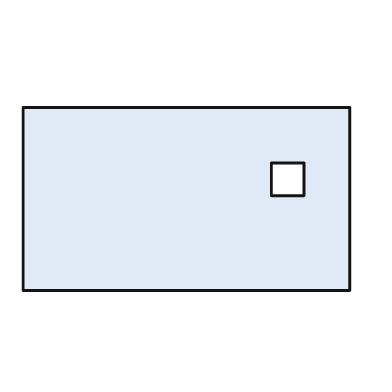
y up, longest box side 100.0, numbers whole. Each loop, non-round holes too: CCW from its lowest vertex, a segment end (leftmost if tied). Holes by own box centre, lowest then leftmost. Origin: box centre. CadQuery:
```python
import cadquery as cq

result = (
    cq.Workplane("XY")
    .moveTo(-50.0, -28.0)
    .lineTo(50.0, -28.0)
    .lineTo(50.0, 28.0)
    .lineTo(-50.0, 28.0)
    .close()
    .moveTo(26.0, 1.0)
    .lineTo(36.0, 1.0)
    .lineTo(36.0, 11.0)
    .lineTo(26.0, 11.0)
    .close()
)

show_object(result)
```